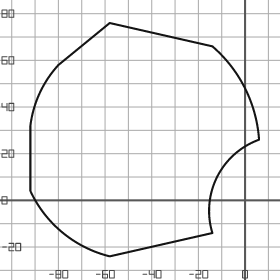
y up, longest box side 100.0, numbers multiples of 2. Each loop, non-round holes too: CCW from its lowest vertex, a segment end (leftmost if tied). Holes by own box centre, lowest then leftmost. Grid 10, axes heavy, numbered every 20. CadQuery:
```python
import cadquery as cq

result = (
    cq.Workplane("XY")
    .moveTo(-58.0, -24.0)
    .lineTo(-14.0, -14.0)
    .threePointArc((-12.0, 10.0), (6.0, 26.0))
    .threePointArc((0.0, 48.0), (-14.0, 66.0))
    .lineTo(-58.0, 76.0)
    .lineTo(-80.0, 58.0)
    .threePointArc((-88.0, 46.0), (-92.0, 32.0))
    .lineTo(-92.0, 4.0)
    .threePointArc((-78.0, -14.0), (-58.0, -24.0))
    .close()
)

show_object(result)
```